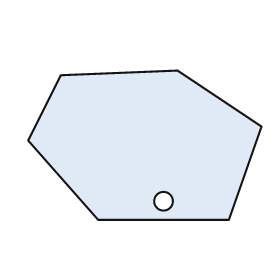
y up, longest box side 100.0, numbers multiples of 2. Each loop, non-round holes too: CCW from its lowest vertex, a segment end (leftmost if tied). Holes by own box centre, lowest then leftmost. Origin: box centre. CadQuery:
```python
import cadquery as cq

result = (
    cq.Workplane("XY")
    .moveTo(-20.0, -32.0)
    .lineTo(36.0, -32.0)
    .lineTo(50.0, 8.0)
    .lineTo(14.0, 32.0)
    .lineTo(-36.0, 30.0)
    .lineTo(-50.0, 2.0)
    .close()
    .moveTo(8.0, -24.0)
    .circle(4.0)
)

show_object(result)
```